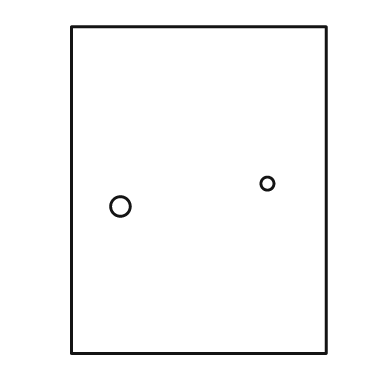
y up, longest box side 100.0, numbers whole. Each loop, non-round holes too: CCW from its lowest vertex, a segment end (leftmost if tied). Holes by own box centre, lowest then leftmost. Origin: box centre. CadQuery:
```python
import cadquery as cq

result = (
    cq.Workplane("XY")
    .moveTo(-39.0, -50.0)
    .lineTo(39.0, -50.0)
    .lineTo(39.0, 50.0)
    .lineTo(-39.0, 50.0)
    .close()
    .moveTo(-24.0, -5.0)
    .circle(3.0)
    .moveTo(21.0, 2.0)
    .circle(2.0)
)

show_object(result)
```